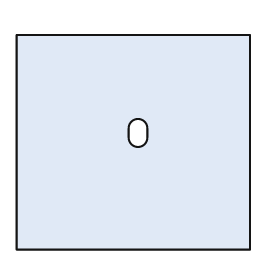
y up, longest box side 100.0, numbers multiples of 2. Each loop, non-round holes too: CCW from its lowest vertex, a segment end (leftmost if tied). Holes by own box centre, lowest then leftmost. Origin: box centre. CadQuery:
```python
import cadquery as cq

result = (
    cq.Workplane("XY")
    .moveTo(-50.0, -46.0)
    .lineTo(50.0, -46.0)
    .lineTo(50.0, 46.0)
    .lineTo(-50.0, 46.0)
    .close()
    .moveTo(-2.0, 2.0)
    .threePointArc((2.0, -2.0), (6.0, 2.0))
    .lineTo(6.0, 6.0)
    .threePointArc((2.0, 10.0), (-2.0, 6.0))
    .close()
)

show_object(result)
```